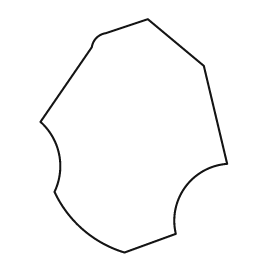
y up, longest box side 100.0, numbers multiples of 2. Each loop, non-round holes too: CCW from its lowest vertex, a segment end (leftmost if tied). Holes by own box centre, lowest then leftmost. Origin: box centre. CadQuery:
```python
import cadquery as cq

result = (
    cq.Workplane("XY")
    .moveTo(-4.0, -50.0)
    .lineTo(18.0, -42.0)
    .threePointArc((22.0, -22.0), (40.0, -12.0))
    .lineTo(30.0, 30.0)
    .lineTo(6.0, 50.0)
    .lineTo(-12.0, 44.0)
    .threePointArc((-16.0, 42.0), (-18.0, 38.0))
    .lineTo(-40.0, 6.0)
    .threePointArc((-32.0, -8.0), (-34.0, -24.0))
    .threePointArc((-22.0, -40.0), (-4.0, -50.0))
    .close()
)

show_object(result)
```